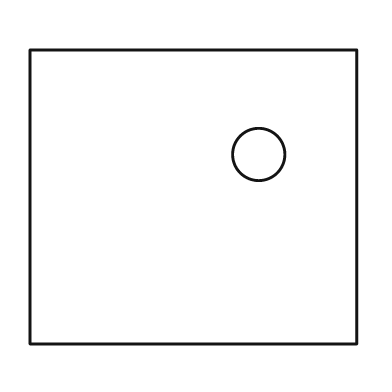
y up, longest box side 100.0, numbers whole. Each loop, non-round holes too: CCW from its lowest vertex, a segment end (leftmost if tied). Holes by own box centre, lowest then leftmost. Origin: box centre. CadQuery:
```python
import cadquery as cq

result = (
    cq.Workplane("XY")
    .moveTo(-50.0, -45.0)
    .lineTo(50.0, -45.0)
    .lineTo(50.0, 45.0)
    .lineTo(-50.0, 45.0)
    .close()
    .moveTo(20.0, 13.0)
    .circle(8.0)
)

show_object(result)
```